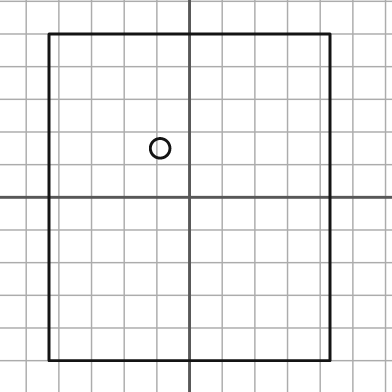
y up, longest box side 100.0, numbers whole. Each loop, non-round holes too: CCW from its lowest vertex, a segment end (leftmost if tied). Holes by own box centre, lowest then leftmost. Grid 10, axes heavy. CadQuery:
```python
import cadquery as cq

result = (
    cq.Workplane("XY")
    .moveTo(-43.0, -50.0)
    .lineTo(43.0, -50.0)
    .lineTo(43.0, 50.0)
    .lineTo(-43.0, 50.0)
    .close()
    .moveTo(-9.0, 15.0)
    .circle(3.0)
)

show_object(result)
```